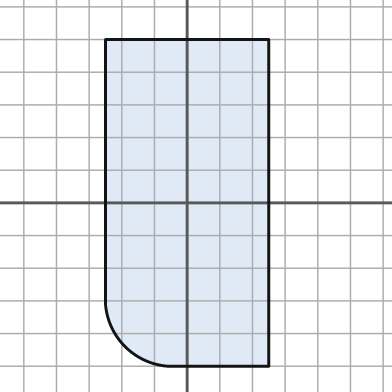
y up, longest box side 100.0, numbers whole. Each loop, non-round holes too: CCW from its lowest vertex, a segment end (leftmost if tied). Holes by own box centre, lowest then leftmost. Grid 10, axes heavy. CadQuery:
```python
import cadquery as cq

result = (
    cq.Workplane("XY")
    .moveTo(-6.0, -50.0)
    .lineTo(25.0, -50.0)
    .lineTo(25.0, 50.0)
    .lineTo(-25.0, 50.0)
    .lineTo(-25.0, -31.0)
    .threePointArc((-19.0, -44.0), (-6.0, -50.0))
    .close()
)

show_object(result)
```